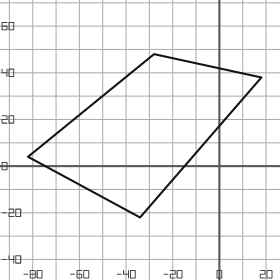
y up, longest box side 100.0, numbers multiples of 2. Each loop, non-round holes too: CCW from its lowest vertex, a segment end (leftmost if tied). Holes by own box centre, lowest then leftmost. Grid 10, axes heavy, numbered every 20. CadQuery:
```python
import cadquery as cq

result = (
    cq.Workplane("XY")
    .moveTo(-34.0, -22.0)
    .lineTo(18.0, 38.0)
    .lineTo(-28.0, 48.0)
    .lineTo(-82.0, 4.0)
    .close()
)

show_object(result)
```